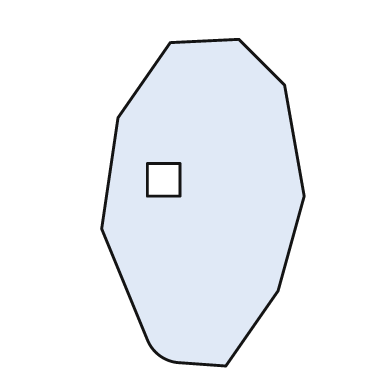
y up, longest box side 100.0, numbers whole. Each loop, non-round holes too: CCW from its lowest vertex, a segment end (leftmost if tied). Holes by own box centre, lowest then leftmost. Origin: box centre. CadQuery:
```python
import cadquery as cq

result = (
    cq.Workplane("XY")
    .moveTo(7.0, -50.0)
    .lineTo(23.0, -27.0)
    .lineTo(31.0, 2.0)
    .lineTo(25.0, 36.0)
    .lineTo(11.0, 50.0)
    .lineTo(-10.0, 49.0)
    .lineTo(-26.0, 26.0)
    .lineTo(-31.0, -8.0)
    .lineTo(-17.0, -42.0)
    .threePointArc((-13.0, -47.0), (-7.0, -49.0))
    .close()
    .moveTo(-17.0, 2.0)
    .lineTo(-7.0, 2.0)
    .lineTo(-7.0, 12.0)
    .lineTo(-17.0, 12.0)
    .close()
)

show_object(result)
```